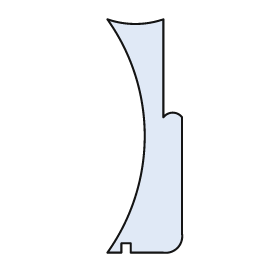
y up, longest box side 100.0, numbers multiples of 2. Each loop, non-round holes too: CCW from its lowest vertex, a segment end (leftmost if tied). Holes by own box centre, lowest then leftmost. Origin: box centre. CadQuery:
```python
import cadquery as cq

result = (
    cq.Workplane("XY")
    .moveTo(-16.0, -50.0)
    .lineTo(-10.0, -50.0)
    .lineTo(-10.0, -46.0)
    .lineTo(-6.0, -46.0)
    .lineTo(-6.0, -50.0)
    .lineTo(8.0, -50.0)
    .threePointArc((14.0, -48.0), (16.0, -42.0))
    .lineTo(16.0, 8.0)
    .threePointArc((12.0, 10.0), (8.0, 8.0))
    .lineTo(8.0, 50.0)
    .threePointArc((-4.0, 48.0), (-16.0, 50.0))
    .threePointArc((0.0, 0.0), (-16.0, -50.0))
    .close()
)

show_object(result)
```